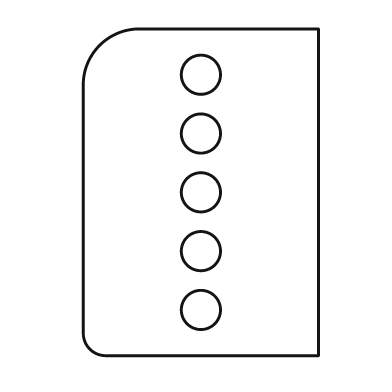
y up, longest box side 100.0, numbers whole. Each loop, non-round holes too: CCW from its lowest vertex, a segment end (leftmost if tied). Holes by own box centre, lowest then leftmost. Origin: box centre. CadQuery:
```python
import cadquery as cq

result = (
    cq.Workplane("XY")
    .moveTo(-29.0, -50.0)
    .lineTo(36.0, -50.0)
    .lineTo(36.0, 50.0)
    .lineTo(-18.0, 50.0)
    .threePointArc((-31.0, 45.0), (-36.0, 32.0))
    .lineTo(-36.0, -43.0)
    .threePointArc((-34.0, -48.0), (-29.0, -50.0))
    .close()
    .moveTo(0.0, -36.0)
    .circle(6.0)
    .moveTo(0.0, -18.0)
    .circle(6.0)
    .moveTo(0.0, 0.0)
    .circle(6.0)
    .moveTo(0.0, 18.0)
    .circle(6.0)
    .moveTo(0.0, 36.0)
    .circle(6.0)
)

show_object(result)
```